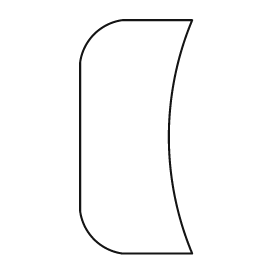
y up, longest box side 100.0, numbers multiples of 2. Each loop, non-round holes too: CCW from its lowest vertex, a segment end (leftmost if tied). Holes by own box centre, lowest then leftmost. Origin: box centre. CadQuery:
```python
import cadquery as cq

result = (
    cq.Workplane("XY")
    .moveTo(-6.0, -50.0)
    .lineTo(24.0, -50.0)
    .threePointArc((14.0, 0.0), (24.0, 50.0))
    .lineTo(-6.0, 50.0)
    .threePointArc((-18.0, 44.0), (-24.0, 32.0))
    .lineTo(-24.0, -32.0)
    .threePointArc((-18.0, -44.0), (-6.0, -50.0))
    .close()
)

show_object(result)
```